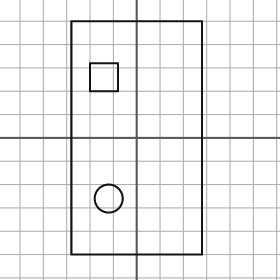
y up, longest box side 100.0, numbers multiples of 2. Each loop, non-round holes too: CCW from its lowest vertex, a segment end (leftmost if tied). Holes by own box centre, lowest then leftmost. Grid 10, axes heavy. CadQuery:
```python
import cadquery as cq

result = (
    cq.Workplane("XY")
    .moveTo(-28.0, -50.0)
    .lineTo(28.0, -50.0)
    .lineTo(28.0, 50.0)
    .lineTo(-28.0, 50.0)
    .close()
    .moveTo(-12.0, -26.0)
    .circle(6.0)
    .moveTo(-20.0, 20.0)
    .lineTo(-8.0, 20.0)
    .lineTo(-8.0, 32.0)
    .lineTo(-20.0, 32.0)
    .close()
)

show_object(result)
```